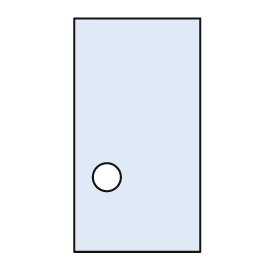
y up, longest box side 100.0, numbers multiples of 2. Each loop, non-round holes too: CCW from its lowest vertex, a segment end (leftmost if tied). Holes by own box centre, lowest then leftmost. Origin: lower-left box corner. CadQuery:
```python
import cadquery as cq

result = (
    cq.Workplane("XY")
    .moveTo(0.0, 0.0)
    .lineTo(54.0, 0.0)
    .lineTo(54.0, 100.0)
    .lineTo(0.0, 100.0)
    .close()
    .moveTo(14.0, 32.0)
    .circle(6.0)
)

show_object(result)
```